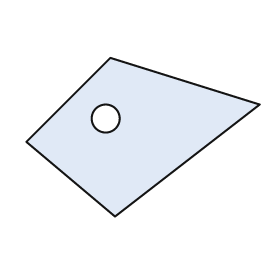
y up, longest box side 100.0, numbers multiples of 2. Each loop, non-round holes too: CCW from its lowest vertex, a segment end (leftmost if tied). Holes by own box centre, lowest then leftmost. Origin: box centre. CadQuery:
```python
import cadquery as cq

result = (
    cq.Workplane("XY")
    .moveTo(-12.0, -34.0)
    .lineTo(50.0, 14.0)
    .lineTo(-14.0, 34.0)
    .lineTo(-50.0, -2.0)
    .close()
    .moveTo(-16.0, 8.0)
    .circle(6.0)
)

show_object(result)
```